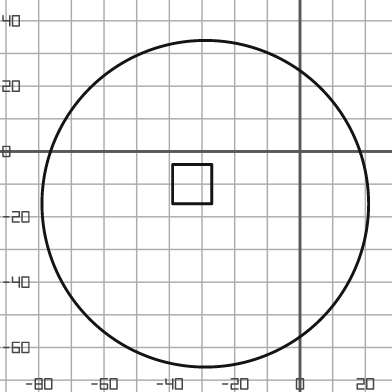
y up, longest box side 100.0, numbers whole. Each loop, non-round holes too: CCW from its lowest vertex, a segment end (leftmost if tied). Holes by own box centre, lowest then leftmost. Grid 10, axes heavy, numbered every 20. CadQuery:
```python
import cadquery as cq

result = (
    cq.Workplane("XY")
    .moveTo(-29.0, -16.0)
    .circle(50.0)
    .moveTo(-39.0, -16.0)
    .lineTo(-27.0, -16.0)
    .lineTo(-27.0, -4.0)
    .lineTo(-39.0, -4.0)
    .close()
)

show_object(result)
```